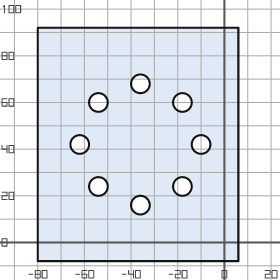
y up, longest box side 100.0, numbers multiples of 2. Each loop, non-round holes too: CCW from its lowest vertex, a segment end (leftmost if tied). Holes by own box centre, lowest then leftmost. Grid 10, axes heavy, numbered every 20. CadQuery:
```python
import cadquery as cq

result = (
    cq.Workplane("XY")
    .moveTo(-80.0, -8.0)
    .lineTo(6.0, -8.0)
    .lineTo(6.0, 92.0)
    .lineTo(-80.0, 92.0)
    .close()
    .moveTo(-36.0, 16.0)
    .circle(4.0)
    .moveTo(-54.0, 24.0)
    .circle(4.0)
    .moveTo(-18.0, 24.0)
    .circle(4.0)
    .moveTo(-62.0, 42.0)
    .circle(4.0)
    .moveTo(-10.0, 42.0)
    .circle(4.0)
    .moveTo(-54.0, 60.0)
    .circle(4.0)
    .moveTo(-18.0, 60.0)
    .circle(4.0)
    .moveTo(-36.0, 68.0)
    .circle(4.0)
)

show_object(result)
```